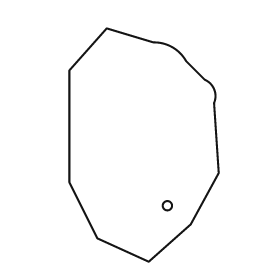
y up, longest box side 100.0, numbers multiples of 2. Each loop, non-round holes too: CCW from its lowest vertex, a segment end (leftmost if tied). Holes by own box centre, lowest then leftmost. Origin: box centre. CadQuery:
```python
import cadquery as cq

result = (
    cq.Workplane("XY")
    .moveTo(2.0, -50.0)
    .lineTo(20.0, -34.0)
    .lineTo(32.0, -12.0)
    .lineTo(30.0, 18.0)
    .threePointArc((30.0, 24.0), (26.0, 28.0))
    .lineTo(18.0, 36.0)
    .threePointArc((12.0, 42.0), (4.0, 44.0))
    .lineTo(-16.0, 50.0)
    .lineTo(-32.0, 32.0)
    .lineTo(-32.0, -16.0)
    .lineTo(-20.0, -40.0)
    .close()
    .moveTo(10.0, -26.0)
    .circle(2.0)
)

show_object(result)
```